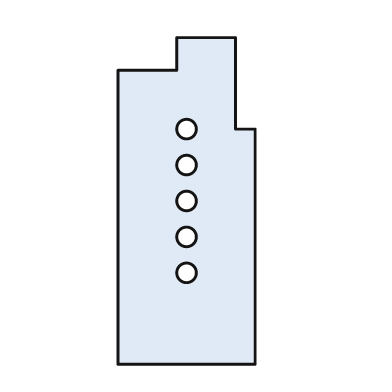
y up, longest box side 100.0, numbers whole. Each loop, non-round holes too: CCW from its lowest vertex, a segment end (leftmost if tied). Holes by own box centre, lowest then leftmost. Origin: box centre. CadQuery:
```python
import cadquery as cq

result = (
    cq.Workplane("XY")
    .moveTo(-21.0, -50.0)
    .lineTo(21.0, -50.0)
    .lineTo(21.0, 22.0)
    .lineTo(15.0, 22.0)
    .lineTo(15.0, 50.0)
    .lineTo(-3.0, 50.0)
    .lineTo(-3.0, 40.0)
    .lineTo(-21.0, 40.0)
    .close()
    .moveTo(0.0, -22.0)
    .circle(3.0)
    .moveTo(0.0, -11.0)
    .circle(3.0)
    .moveTo(0.0, 0.0)
    .circle(3.0)
    .moveTo(0.0, 11.0)
    .circle(3.0)
    .moveTo(0.0, 22.0)
    .circle(3.0)
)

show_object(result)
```